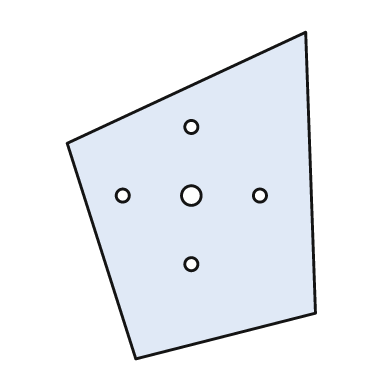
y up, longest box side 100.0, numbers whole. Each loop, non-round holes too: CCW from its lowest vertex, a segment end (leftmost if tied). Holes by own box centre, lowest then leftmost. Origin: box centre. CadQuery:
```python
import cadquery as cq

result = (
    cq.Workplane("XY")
    .moveTo(-17.0, -50.0)
    .lineTo(38.0, -36.0)
    .lineTo(35.0, 50.0)
    .lineTo(-38.0, 16.0)
    .close()
    .moveTo(0.0, -21.0)
    .circle(2.0)
    .moveTo(-21.0, 0.0)
    .circle(2.0)
    .moveTo(0.0, 0.0)
    .circle(3.0)
    .moveTo(21.0, 0.0)
    .circle(2.0)
    .moveTo(0.0, 21.0)
    .circle(2.0)
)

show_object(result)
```